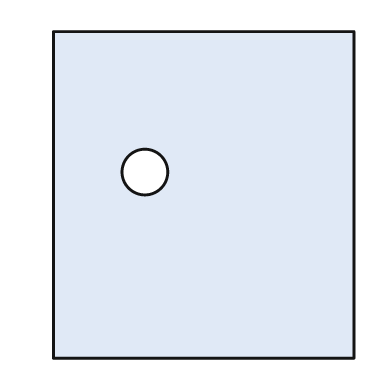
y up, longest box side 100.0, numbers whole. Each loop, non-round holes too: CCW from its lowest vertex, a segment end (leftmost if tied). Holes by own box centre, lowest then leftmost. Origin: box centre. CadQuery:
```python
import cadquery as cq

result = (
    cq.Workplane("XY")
    .moveTo(-46.0, -50.0)
    .lineTo(46.0, -50.0)
    .lineTo(46.0, 50.0)
    .lineTo(-46.0, 50.0)
    .close()
    .moveTo(-18.0, 7.0)
    .circle(7.0)
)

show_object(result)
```